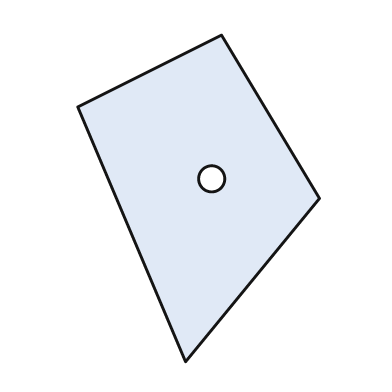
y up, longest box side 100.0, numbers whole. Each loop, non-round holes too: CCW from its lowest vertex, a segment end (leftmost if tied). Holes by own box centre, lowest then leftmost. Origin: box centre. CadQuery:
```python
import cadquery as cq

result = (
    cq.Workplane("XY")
    .moveTo(-4.0, -50.0)
    .lineTo(37.0, 0.0)
    .lineTo(7.0, 50.0)
    .lineTo(-37.0, 28.0)
    .close()
    .moveTo(4.0, 6.0)
    .circle(4.0)
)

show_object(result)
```